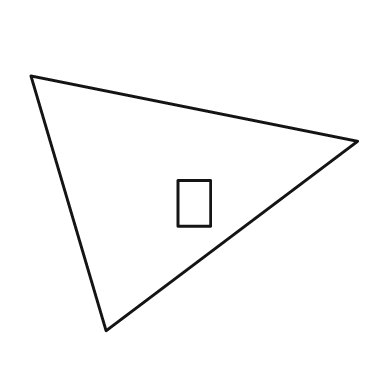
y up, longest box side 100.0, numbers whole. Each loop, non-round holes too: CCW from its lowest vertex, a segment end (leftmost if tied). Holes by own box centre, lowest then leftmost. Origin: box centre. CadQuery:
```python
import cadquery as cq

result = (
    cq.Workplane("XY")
    .moveTo(-27.0, -39.0)
    .lineTo(50.0, 19.0)
    .lineTo(-50.0, 39.0)
    .close()
    .moveTo(-5.0, -7.0)
    .lineTo(5.0, -7.0)
    .lineTo(5.0, 7.0)
    .lineTo(-5.0, 7.0)
    .close()
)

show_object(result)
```